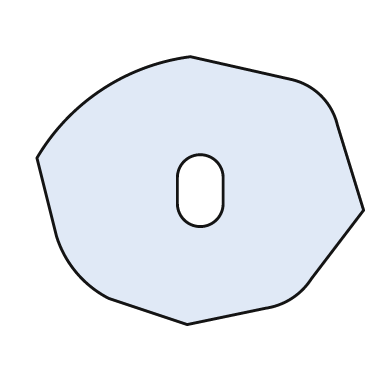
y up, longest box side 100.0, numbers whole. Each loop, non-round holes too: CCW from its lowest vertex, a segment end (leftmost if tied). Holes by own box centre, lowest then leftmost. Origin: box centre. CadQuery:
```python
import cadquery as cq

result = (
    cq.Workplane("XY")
    .moveTo(-4.0, -41.0)
    .lineTo(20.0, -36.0)
    .threePointArc((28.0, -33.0), (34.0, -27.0))
    .lineTo(50.0, -6.0)
    .lineTo(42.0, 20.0)
    .threePointArc((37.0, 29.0), (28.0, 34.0))
    .lineTo(-3.0, 41.0)
    .threePointArc((-30.0, 31.0), (-50.0, 10.0))
    .lineTo(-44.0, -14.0)
    .threePointArc((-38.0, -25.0), (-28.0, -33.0))
    .close()
    .moveTo(-7.0, -4.0)
    .threePointArc((0.0, -11.0), (7.0, -4.0))
    .lineTo(7.0, 4.0)
    .threePointArc((0.0, 11.0), (-7.0, 4.0))
    .close()
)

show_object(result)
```